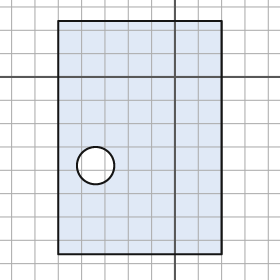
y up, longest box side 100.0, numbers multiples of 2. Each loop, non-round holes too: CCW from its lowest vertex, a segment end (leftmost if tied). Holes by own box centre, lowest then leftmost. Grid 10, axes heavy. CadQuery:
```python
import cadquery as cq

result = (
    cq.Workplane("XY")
    .moveTo(-50.0, -76.0)
    .lineTo(20.0, -76.0)
    .lineTo(20.0, 24.0)
    .lineTo(-50.0, 24.0)
    .close()
    .moveTo(-34.0, -38.0)
    .circle(8.0)
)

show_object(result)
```